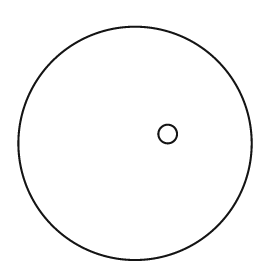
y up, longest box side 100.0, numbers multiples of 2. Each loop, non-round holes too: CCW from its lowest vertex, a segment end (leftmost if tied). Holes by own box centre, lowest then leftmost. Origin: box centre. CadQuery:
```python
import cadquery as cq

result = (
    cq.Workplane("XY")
    .moveTo(0.0, 0.0)
    .circle(50.0)
    .moveTo(14.0, 4.0)
    .circle(4.0)
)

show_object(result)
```